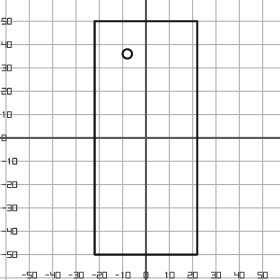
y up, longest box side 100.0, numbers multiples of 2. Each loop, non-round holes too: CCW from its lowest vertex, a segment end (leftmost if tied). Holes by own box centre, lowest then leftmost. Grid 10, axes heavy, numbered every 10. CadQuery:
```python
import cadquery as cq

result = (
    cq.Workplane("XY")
    .moveTo(-22.0, -50.0)
    .lineTo(22.0, -50.0)
    .lineTo(22.0, 50.0)
    .lineTo(-22.0, 50.0)
    .close()
    .moveTo(-8.0, 36.0)
    .circle(2.0)
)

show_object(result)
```